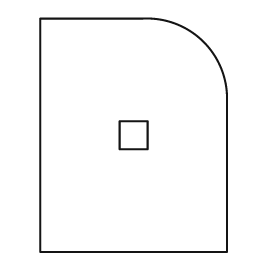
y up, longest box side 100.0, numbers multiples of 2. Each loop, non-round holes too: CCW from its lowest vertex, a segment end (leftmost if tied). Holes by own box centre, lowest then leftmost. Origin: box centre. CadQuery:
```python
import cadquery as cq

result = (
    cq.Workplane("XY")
    .moveTo(-40.0, -50.0)
    .lineTo(40.0, -50.0)
    .lineTo(40.0, 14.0)
    .threePointArc((30.0, 40.0), (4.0, 50.0))
    .lineTo(-40.0, 50.0)
    .close()
    .moveTo(-6.0, -6.0)
    .lineTo(6.0, -6.0)
    .lineTo(6.0, 6.0)
    .lineTo(-6.0, 6.0)
    .close()
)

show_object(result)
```